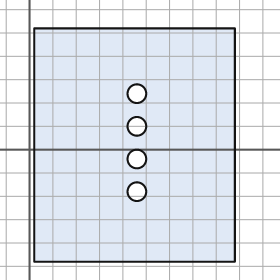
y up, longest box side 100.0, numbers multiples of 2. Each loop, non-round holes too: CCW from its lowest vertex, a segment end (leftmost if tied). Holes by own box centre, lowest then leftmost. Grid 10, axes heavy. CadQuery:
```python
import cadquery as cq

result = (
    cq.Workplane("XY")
    .moveTo(2.0, -48.0)
    .lineTo(88.0, -48.0)
    .lineTo(88.0, 52.0)
    .lineTo(2.0, 52.0)
    .close()
    .moveTo(46.0, -18.0)
    .circle(4.0)
    .moveTo(46.0, -4.0)
    .circle(4.0)
    .moveTo(46.0, 10.0)
    .circle(4.0)
    .moveTo(46.0, 24.0)
    .circle(4.0)
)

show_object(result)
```